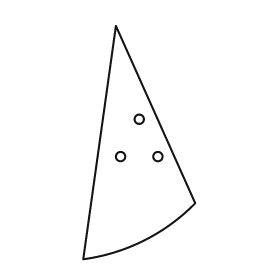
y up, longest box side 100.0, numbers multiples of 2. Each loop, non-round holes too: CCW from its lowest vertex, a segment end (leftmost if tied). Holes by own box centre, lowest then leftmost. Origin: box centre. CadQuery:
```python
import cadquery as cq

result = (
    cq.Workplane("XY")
    .moveTo(-24.0, -50.0)
    .threePointArc((2.0, -42.0), (24.0, -26.0))
    .lineTo(-10.0, 50.0)
    .close()
    .moveTo(-8.0, -6.0)
    .circle(2.0)
    .moveTo(8.0, -6.0)
    .circle(2.0)
    .moveTo(0.0, 10.0)
    .circle(2.0)
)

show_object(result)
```